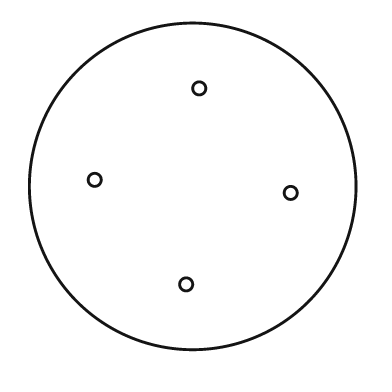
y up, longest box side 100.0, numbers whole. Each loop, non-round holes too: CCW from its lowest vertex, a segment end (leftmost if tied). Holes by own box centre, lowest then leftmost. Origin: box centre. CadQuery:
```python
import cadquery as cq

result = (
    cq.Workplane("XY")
    .moveTo(0.0, 0.0)
    .circle(50.0)
    .moveTo(-2.0, -30.0)
    .circle(2.0)
    .moveTo(30.0, -2.0)
    .circle(2.0)
    .moveTo(-30.0, 2.0)
    .circle(2.0)
    .moveTo(2.0, 30.0)
    .circle(2.0)
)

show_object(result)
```